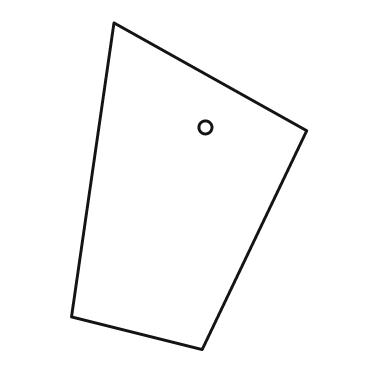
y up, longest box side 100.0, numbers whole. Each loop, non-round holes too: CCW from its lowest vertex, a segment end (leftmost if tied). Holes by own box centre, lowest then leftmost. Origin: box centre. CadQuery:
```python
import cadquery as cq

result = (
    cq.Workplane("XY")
    .moveTo(4.0, -50.0)
    .lineTo(36.0, 17.0)
    .lineTo(-23.0, 50.0)
    .lineTo(-36.0, -40.0)
    .close()
    .moveTo(5.0, 18.0)
    .circle(2.0)
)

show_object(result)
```